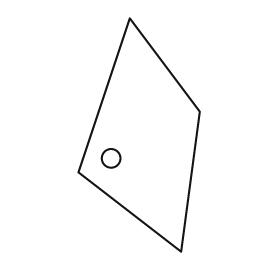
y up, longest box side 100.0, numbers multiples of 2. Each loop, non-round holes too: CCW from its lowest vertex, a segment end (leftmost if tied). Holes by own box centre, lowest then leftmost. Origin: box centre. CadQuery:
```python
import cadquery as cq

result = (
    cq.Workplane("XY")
    .moveTo(18.0, -50.0)
    .lineTo(26.0, 10.0)
    .lineTo(-4.0, 50.0)
    .lineTo(-26.0, -16.0)
    .close()
    .moveTo(-12.0, -10.0)
    .circle(4.0)
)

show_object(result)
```